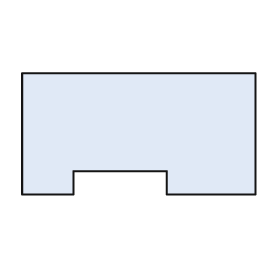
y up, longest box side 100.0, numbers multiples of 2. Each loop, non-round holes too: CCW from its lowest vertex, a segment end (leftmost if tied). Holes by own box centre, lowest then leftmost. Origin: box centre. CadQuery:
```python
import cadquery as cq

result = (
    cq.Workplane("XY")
    .moveTo(-50.0, -26.0)
    .lineTo(-28.0, -26.0)
    .lineTo(-28.0, -16.0)
    .lineTo(12.0, -16.0)
    .lineTo(12.0, -26.0)
    .lineTo(50.0, -26.0)
    .lineTo(50.0, 26.0)
    .lineTo(-50.0, 26.0)
    .close()
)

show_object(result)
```